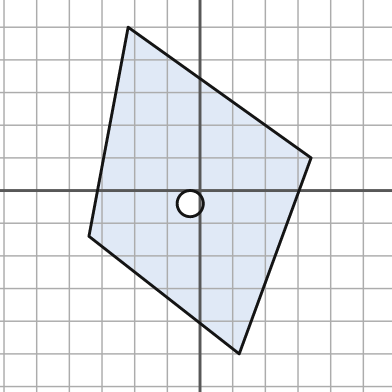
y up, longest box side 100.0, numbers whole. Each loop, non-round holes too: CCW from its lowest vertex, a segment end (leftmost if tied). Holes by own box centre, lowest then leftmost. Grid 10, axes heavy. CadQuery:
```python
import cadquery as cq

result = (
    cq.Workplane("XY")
    .moveTo(12.0, -50.0)
    .lineTo(34.0, 10.0)
    .lineTo(-22.0, 50.0)
    .lineTo(-34.0, -14.0)
    .close()
    .moveTo(-3.0, -4.0)
    .circle(4.0)
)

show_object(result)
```